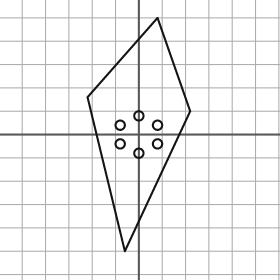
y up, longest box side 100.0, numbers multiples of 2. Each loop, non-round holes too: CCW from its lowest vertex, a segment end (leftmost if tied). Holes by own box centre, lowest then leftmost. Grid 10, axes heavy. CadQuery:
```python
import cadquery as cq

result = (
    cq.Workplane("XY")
    .moveTo(-6.0, -50.0)
    .lineTo(22.0, 10.0)
    .lineTo(8.0, 50.0)
    .lineTo(-22.0, 16.0)
    .close()
    .moveTo(0.0, -8.0)
    .circle(2.0)
    .moveTo(-8.0, -4.0)
    .circle(2.0)
    .moveTo(8.0, -4.0)
    .circle(2.0)
    .moveTo(-8.0, 4.0)
    .circle(2.0)
    .moveTo(8.0, 4.0)
    .circle(2.0)
    .moveTo(0.0, 8.0)
    .circle(2.0)
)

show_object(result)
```